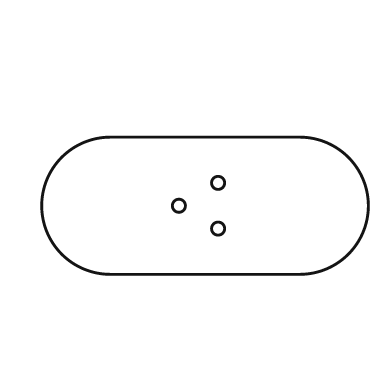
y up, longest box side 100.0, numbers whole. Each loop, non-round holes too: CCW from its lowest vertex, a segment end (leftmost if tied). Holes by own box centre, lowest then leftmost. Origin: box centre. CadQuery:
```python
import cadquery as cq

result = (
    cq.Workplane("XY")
    .moveTo(-29.0, -21.0)
    .lineTo(29.0, -21.0)
    .threePointArc((50.0, 0.0), (29.0, 21.0))
    .lineTo(-29.0, 21.0)
    .threePointArc((-50.0, 0.0), (-29.0, -21.0))
    .close()
    .moveTo(4.0, -7.0)
    .circle(2.0)
    .moveTo(-8.0, 0.0)
    .circle(2.0)
    .moveTo(4.0, 7.0)
    .circle(2.0)
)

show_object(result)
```